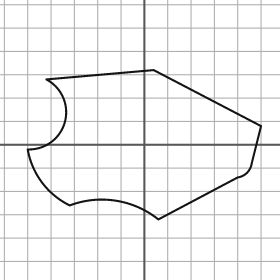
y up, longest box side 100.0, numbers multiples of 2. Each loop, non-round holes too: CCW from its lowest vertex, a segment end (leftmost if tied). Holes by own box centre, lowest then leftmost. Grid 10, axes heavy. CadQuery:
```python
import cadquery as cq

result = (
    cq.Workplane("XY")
    .moveTo(6.0, -32.0)
    .lineTo(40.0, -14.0)
    .threePointArc((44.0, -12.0), (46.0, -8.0))
    .lineTo(50.0, 8.0)
    .lineTo(4.0, 32.0)
    .lineTo(-42.0, 28.0)
    .threePointArc((-34.0, 10.0), (-50.0, -2.0))
    .threePointArc((-44.0, -16.0), (-32.0, -26.0))
    .threePointArc((-12.0, -24.0), (6.0, -32.0))
    .close()
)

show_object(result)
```